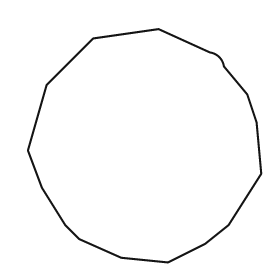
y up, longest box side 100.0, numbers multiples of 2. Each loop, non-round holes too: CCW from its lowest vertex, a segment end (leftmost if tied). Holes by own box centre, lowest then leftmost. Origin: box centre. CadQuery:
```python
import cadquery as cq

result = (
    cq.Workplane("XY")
    .moveTo(10.0, -50.0)
    .lineTo(26.0, -42.0)
    .lineTo(36.0, -34.0)
    .lineTo(50.0, -12.0)
    .lineTo(48.0, 10.0)
    .lineTo(44.0, 22.0)
    .lineTo(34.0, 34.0)
    .threePointArc((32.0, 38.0), (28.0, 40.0))
    .lineTo(6.0, 50.0)
    .lineTo(-22.0, 46.0)
    .lineTo(-42.0, 26.0)
    .lineTo(-50.0, -2.0)
    .lineTo(-44.0, -18.0)
    .lineTo(-34.0, -34.0)
    .lineTo(-28.0, -40.0)
    .lineTo(-10.0, -48.0)
    .close()
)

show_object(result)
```